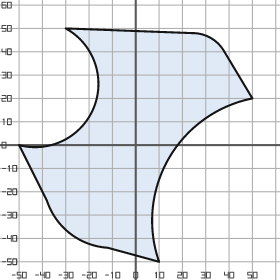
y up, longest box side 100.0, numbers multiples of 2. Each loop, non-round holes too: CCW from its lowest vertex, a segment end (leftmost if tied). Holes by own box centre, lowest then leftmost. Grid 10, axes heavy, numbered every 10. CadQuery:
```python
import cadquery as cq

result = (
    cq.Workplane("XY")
    .moveTo(10.0, -50.0)
    .threePointArc((14.0, -6.0), (50.0, 20.0))
    .lineTo(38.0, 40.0)
    .threePointArc((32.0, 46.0), (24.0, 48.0))
    .lineTo(-30.0, 50.0)
    .threePointArc((-18.0, 16.0), (-50.0, 0.0))
    .lineTo(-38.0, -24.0)
    .threePointArc((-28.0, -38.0), (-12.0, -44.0))
    .close()
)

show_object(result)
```